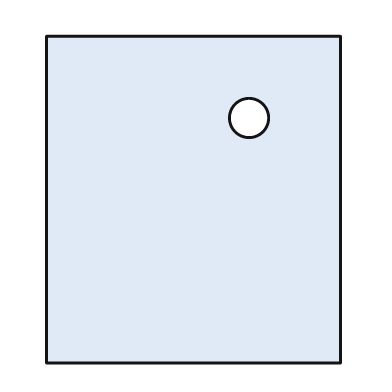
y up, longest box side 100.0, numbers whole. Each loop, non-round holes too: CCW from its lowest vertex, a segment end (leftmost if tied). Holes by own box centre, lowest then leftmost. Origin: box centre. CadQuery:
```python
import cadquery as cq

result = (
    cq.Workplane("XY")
    .moveTo(-45.0, -50.0)
    .lineTo(45.0, -50.0)
    .lineTo(45.0, 50.0)
    .lineTo(-45.0, 50.0)
    .close()
    .moveTo(17.0, 25.0)
    .circle(6.0)
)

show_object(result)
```